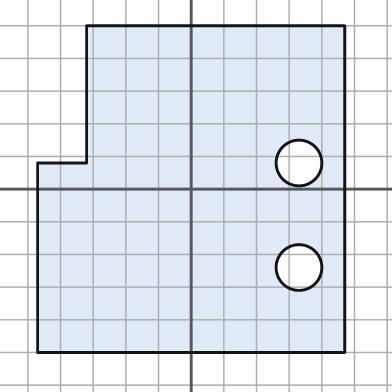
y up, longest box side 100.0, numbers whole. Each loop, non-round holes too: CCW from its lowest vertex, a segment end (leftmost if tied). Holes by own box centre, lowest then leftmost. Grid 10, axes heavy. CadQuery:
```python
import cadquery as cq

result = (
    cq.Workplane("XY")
    .moveTo(-47.0, -50.0)
    .lineTo(47.0, -50.0)
    .lineTo(47.0, 50.0)
    .lineTo(-32.0, 50.0)
    .lineTo(-32.0, 8.0)
    .lineTo(-47.0, 8.0)
    .close()
    .moveTo(33.0, -24.0)
    .circle(7.0)
    .moveTo(33.0, 8.0)
    .circle(7.0)
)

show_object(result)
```